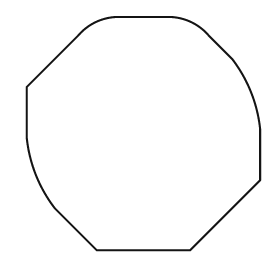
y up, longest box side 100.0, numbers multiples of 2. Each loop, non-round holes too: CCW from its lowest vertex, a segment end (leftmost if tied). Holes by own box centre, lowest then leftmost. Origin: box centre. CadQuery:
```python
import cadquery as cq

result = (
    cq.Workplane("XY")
    .moveTo(-20.0, -50.0)
    .lineTo(20.0, -50.0)
    .lineTo(50.0, -20.0)
    .lineTo(50.0, 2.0)
    .threePointArc((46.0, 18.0), (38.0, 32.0))
    .lineTo(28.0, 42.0)
    .threePointArc((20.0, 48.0), (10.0, 50.0))
    .lineTo(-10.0, 50.0)
    .threePointArc((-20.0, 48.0), (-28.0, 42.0))
    .lineTo(-50.0, 20.0)
    .lineTo(-50.0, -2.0)
    .threePointArc((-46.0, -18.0), (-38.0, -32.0))
    .close()
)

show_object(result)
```